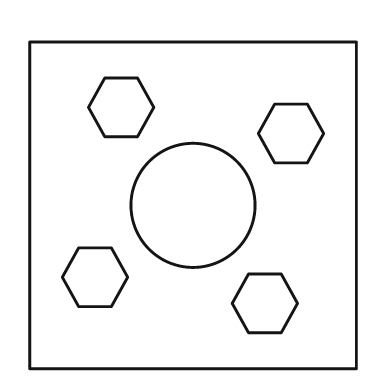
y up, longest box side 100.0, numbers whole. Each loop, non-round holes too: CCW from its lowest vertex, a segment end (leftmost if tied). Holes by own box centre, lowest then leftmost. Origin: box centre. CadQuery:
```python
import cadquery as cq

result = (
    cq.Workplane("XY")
    .moveTo(-50.0, -50.0)
    .lineTo(50.0, -50.0)
    .lineTo(50.0, 50.0)
    .lineTo(-50.0, 50.0)
    .close()
    .moveTo(17.0, -39.0)
    .lineTo(27.0, -39.0)
    .lineTo(32.0, -30.0)
    .lineTo(27.0, -21.0)
    .lineTo(17.0, -21.0)
    .lineTo(12.0, -30.0)
    .close()
    .moveTo(-35.0, -31.0)
    .lineTo(-25.0, -31.0)
    .lineTo(-20.0, -22.0)
    .lineTo(-25.0, -13.0)
    .lineTo(-35.0, -13.0)
    .lineTo(-40.0, -22.0)
    .close()
    .moveTo(0.0, 0.0)
    .circle(19.0)
    .moveTo(25.0, 13.0)
    .lineTo(35.0, 13.0)
    .lineTo(40.0, 22.0)
    .lineTo(35.0, 31.0)
    .lineTo(25.0, 31.0)
    .lineTo(20.0, 22.0)
    .close()
    .moveTo(-27.0, 21.0)
    .lineTo(-17.0, 21.0)
    .lineTo(-12.0, 30.0)
    .lineTo(-17.0, 39.0)
    .lineTo(-27.0, 39.0)
    .lineTo(-32.0, 30.0)
    .close()
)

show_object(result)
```